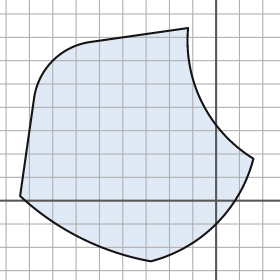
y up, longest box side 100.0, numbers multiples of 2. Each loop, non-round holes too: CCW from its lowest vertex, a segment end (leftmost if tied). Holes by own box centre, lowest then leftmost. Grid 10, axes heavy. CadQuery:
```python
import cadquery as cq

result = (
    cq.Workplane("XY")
    .moveTo(-28.0, -26.0)
    .threePointArc((0.0, -10.0), (16.0, 18.0))
    .threePointArc((-6.0, 42.0), (-12.0, 74.0))
    .lineTo(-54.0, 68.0)
    .threePointArc((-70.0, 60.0), (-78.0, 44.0))
    .lineTo(-84.0, 2.0)
    .threePointArc((-58.0, -16.0), (-28.0, -26.0))
    .close()
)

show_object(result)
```